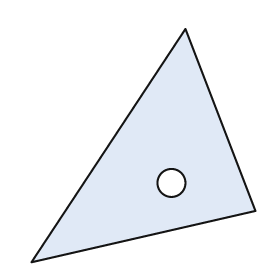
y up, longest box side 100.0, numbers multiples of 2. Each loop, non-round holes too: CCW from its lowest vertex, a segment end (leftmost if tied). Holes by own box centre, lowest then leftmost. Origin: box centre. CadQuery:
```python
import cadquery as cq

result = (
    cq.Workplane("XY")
    .moveTo(-48.0, -50.0)
    .lineTo(48.0, -28.0)
    .lineTo(18.0, 50.0)
    .close()
    .moveTo(12.0, -16.0)
    .circle(6.0)
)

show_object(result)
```